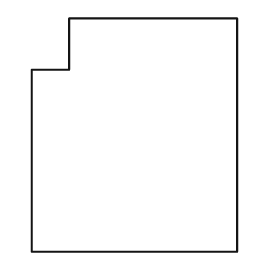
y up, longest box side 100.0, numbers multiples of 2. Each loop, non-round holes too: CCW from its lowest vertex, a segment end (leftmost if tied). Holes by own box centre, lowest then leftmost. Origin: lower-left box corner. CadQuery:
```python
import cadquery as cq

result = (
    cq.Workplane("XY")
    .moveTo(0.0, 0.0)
    .lineTo(88.0, 0.0)
    .lineTo(88.0, 100.0)
    .lineTo(16.0, 100.0)
    .lineTo(16.0, 78.0)
    .lineTo(0.0, 78.0)
    .close()
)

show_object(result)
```